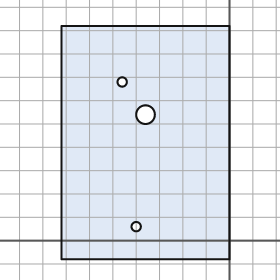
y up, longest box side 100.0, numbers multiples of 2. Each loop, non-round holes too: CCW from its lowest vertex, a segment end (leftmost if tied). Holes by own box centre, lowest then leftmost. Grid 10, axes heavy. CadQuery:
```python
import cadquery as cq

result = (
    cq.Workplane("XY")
    .moveTo(-72.0, -8.0)
    .lineTo(0.0, -8.0)
    .lineTo(0.0, 92.0)
    .lineTo(-72.0, 92.0)
    .close()
    .moveTo(-40.0, 6.0)
    .circle(2.0)
    .moveTo(-36.0, 54.0)
    .circle(4.0)
    .moveTo(-46.0, 68.0)
    .circle(2.0)
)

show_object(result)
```